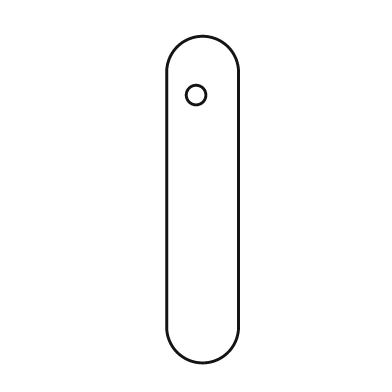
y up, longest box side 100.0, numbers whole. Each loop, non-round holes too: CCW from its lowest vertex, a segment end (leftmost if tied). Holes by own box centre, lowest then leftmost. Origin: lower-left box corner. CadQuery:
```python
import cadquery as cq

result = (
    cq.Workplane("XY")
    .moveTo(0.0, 11.0)
    .threePointArc((11.0, 0.0), (22.0, 11.0))
    .lineTo(22.0, 89.0)
    .threePointArc((11.0, 100.0), (0.0, 89.0))
    .close()
    .moveTo(9.0, 82.0)
    .circle(3.0)
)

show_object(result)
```